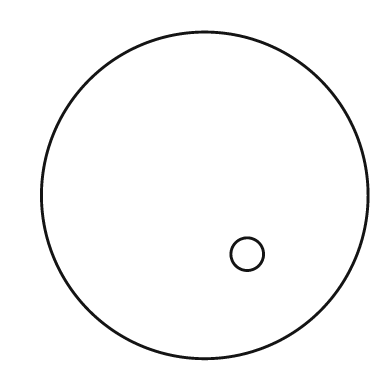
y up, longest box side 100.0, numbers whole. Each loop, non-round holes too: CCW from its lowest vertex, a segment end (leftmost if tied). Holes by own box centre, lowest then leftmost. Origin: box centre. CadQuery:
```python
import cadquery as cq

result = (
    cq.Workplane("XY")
    .moveTo(0.0, 0.0)
    .circle(50.0)
    .moveTo(13.0, -18.0)
    .circle(5.0)
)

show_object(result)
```